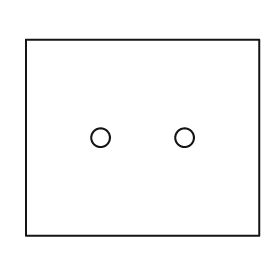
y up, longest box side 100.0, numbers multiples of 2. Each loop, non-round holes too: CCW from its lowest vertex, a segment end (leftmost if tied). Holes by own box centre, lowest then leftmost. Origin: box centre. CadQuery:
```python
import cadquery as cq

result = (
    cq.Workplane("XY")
    .moveTo(-50.0, -42.0)
    .lineTo(50.0, -42.0)
    .lineTo(50.0, 42.0)
    .lineTo(-50.0, 42.0)
    .close()
    .moveTo(-18.0, 0.0)
    .circle(4.0)
    .moveTo(18.0, 0.0)
    .circle(4.0)
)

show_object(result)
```